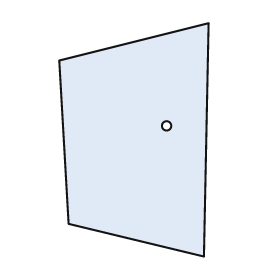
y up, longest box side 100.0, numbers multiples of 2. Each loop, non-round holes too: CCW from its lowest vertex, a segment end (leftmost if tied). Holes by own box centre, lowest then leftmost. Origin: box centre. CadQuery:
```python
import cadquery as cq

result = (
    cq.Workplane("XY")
    .moveTo(30.0, -50.0)
    .lineTo(32.0, 50.0)
    .lineTo(-32.0, 34.0)
    .lineTo(-28.0, -36.0)
    .close()
    .moveTo(14.0, 6.0)
    .circle(2.0)
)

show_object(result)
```